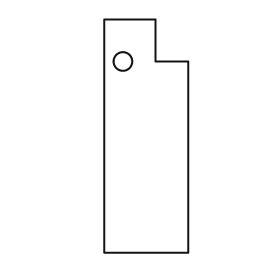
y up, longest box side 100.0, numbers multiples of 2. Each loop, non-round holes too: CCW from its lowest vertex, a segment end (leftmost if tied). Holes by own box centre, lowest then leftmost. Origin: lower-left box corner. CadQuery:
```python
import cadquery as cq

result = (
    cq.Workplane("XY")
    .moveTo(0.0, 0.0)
    .lineTo(36.0, 0.0)
    .lineTo(36.0, 82.0)
    .lineTo(22.0, 82.0)
    .lineTo(22.0, 100.0)
    .lineTo(0.0, 100.0)
    .close()
    .moveTo(8.0, 82.0)
    .circle(4.0)
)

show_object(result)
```